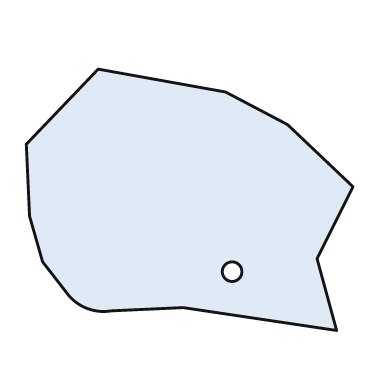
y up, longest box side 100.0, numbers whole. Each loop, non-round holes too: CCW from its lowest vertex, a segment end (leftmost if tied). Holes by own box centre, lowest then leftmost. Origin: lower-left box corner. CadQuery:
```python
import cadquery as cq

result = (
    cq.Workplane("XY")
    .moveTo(95.0, 0.0)
    .lineTo(89.0, 22.0)
    .lineTo(100.0, 44.0)
    .lineTo(80.0, 63.0)
    .lineTo(61.0, 73.0)
    .lineTo(22.0, 80.0)
    .lineTo(0.0, 57.0)
    .lineTo(1.0, 35.0)
    .lineTo(5.0, 21.0)
    .lineTo(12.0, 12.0)
    .threePointArc((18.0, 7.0), (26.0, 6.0))
    .lineTo(48.0, 7.0)
    .close()
    .moveTo(63.0, 18.0)
    .circle(3.0)
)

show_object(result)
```